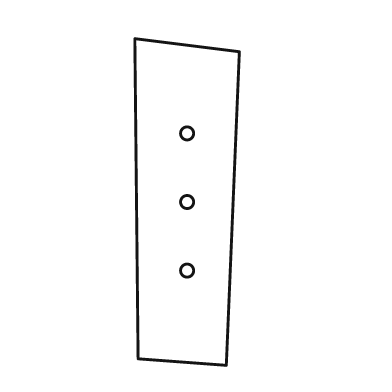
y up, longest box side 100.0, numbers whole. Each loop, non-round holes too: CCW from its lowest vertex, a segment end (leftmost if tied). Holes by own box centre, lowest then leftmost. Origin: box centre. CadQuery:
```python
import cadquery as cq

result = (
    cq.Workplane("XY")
    .moveTo(12.0, -50.0)
    .lineTo(16.0, 46.0)
    .lineTo(-16.0, 50.0)
    .lineTo(-15.0, -48.0)
    .close()
    .moveTo(0.0, -21.0)
    .circle(2.0)
    .moveTo(0.0, 0.0)
    .circle(2.0)
    .moveTo(0.0, 21.0)
    .circle(2.0)
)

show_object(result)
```